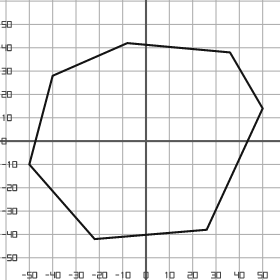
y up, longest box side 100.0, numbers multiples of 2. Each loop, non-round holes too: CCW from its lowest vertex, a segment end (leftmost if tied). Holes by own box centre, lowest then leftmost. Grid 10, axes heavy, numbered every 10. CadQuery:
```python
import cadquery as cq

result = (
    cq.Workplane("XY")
    .moveTo(-22.0, -42.0)
    .lineTo(26.0, -38.0)
    .lineTo(50.0, 14.0)
    .lineTo(36.0, 38.0)
    .lineTo(-8.0, 42.0)
    .lineTo(-40.0, 28.0)
    .lineTo(-50.0, -10.0)
    .close()
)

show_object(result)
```